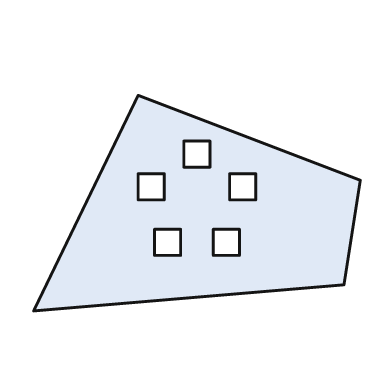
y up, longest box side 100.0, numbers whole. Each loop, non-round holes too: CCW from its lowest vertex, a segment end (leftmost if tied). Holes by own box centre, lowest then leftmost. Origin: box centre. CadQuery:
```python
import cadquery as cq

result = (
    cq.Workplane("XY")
    .moveTo(-50.0, -33.0)
    .lineTo(45.0, -25.0)
    .lineTo(50.0, 7.0)
    .lineTo(-18.0, 33.0)
    .close()
    .moveTo(-13.0, -16.0)
    .lineTo(-5.0, -16.0)
    .lineTo(-5.0, -8.0)
    .lineTo(-13.0, -8.0)
    .close()
    .moveTo(5.0, -16.0)
    .lineTo(13.0, -16.0)
    .lineTo(13.0, -8.0)
    .lineTo(5.0, -8.0)
    .close()
    .moveTo(-18.0, 1.0)
    .lineTo(-10.0, 1.0)
    .lineTo(-10.0, 9.0)
    .lineTo(-18.0, 9.0)
    .close()
    .moveTo(10.0, 1.0)
    .lineTo(18.0, 1.0)
    .lineTo(18.0, 9.0)
    .lineTo(10.0, 9.0)
    .close()
    .moveTo(-4.0, 11.0)
    .lineTo(4.0, 11.0)
    .lineTo(4.0, 19.0)
    .lineTo(-4.0, 19.0)
    .close()
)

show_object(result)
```